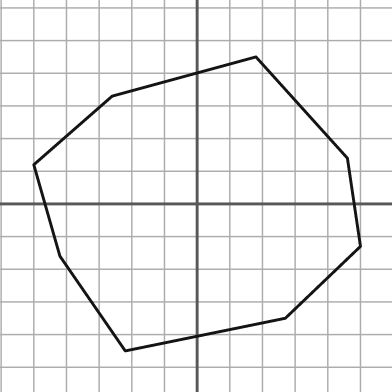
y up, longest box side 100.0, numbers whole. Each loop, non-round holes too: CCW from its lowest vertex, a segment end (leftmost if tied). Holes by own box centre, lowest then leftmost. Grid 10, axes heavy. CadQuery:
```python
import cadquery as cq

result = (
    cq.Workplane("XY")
    .moveTo(-22.0, -45.0)
    .lineTo(27.0, -35.0)
    .lineTo(50.0, -13.0)
    .lineTo(46.0, 14.0)
    .lineTo(18.0, 45.0)
    .lineTo(-26.0, 33.0)
    .lineTo(-50.0, 12.0)
    .lineTo(-42.0, -16.0)
    .close()
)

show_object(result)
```